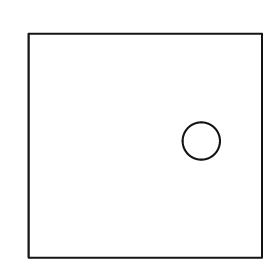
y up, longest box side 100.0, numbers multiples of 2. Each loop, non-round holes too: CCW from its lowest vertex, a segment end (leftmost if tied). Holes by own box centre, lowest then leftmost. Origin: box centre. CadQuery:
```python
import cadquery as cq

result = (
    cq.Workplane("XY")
    .moveTo(-50.0, -48.0)
    .lineTo(50.0, -48.0)
    .lineTo(50.0, 48.0)
    .lineTo(-50.0, 48.0)
    .close()
    .moveTo(24.0, 2.0)
    .circle(8.0)
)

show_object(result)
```